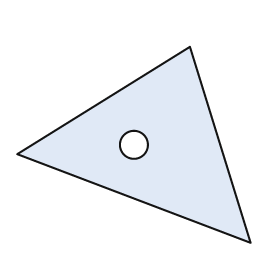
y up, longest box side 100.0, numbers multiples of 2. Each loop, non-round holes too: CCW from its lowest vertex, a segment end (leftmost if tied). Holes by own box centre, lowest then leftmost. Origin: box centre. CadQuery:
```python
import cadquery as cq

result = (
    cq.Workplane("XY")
    .moveTo(50.0, -42.0)
    .lineTo(24.0, 42.0)
    .lineTo(-50.0, -4.0)
    .close()
    .moveTo(0.0, 0.0)
    .circle(6.0)
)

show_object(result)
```